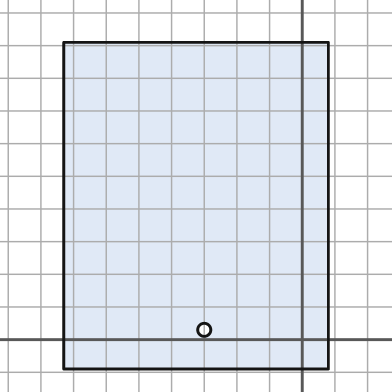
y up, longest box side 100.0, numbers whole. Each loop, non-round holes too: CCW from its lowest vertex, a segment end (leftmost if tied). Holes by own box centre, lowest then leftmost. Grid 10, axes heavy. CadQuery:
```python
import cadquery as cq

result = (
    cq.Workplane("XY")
    .moveTo(-73.0, -9.0)
    .lineTo(8.0, -9.0)
    .lineTo(8.0, 91.0)
    .lineTo(-73.0, 91.0)
    .close()
    .moveTo(-30.0, 3.0)
    .circle(2.0)
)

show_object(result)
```